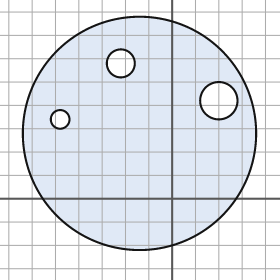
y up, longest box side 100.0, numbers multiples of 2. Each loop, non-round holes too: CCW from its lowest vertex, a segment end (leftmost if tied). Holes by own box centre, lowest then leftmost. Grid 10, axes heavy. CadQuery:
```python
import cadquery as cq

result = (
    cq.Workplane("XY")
    .moveTo(-14.0, 28.0)
    .circle(50.0)
    .moveTo(-48.0, 34.0)
    .circle(4.0)
    .moveTo(20.0, 42.0)
    .circle(8.0)
    .moveTo(-22.0, 58.0)
    .circle(6.0)
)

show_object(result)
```